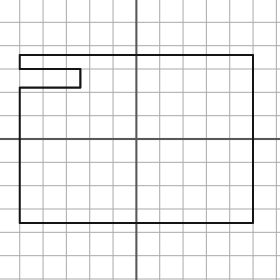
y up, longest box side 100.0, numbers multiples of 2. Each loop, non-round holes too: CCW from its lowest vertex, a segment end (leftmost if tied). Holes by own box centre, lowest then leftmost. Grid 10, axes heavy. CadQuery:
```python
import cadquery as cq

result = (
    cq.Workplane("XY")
    .moveTo(-50.0, -36.0)
    .lineTo(50.0, -36.0)
    .lineTo(50.0, 36.0)
    .lineTo(-50.0, 36.0)
    .lineTo(-50.0, 30.0)
    .lineTo(-24.0, 30.0)
    .lineTo(-24.0, 22.0)
    .lineTo(-50.0, 22.0)
    .close()
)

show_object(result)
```